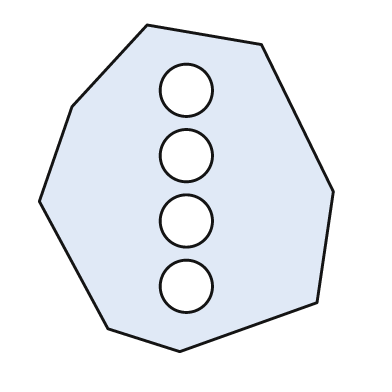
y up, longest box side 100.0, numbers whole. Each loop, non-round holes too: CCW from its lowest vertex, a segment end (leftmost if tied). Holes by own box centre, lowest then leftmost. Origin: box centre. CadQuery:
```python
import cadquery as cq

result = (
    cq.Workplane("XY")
    .moveTo(-2.0, -50.0)
    .lineTo(40.0, -35.0)
    .lineTo(45.0, -1.0)
    .lineTo(23.0, 44.0)
    .lineTo(-12.0, 50.0)
    .lineTo(-35.0, 25.0)
    .lineTo(-45.0, -4.0)
    .lineTo(-24.0, -43.0)
    .close()
    .moveTo(0.0, -30.0)
    .circle(8.0)
    .moveTo(0.0, -10.0)
    .circle(8.0)
    .moveTo(0.0, 10.0)
    .circle(8.0)
    .moveTo(0.0, 30.0)
    .circle(8.0)
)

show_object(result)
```